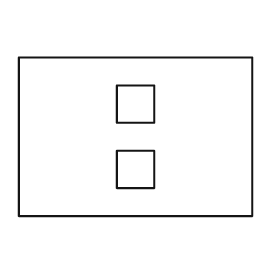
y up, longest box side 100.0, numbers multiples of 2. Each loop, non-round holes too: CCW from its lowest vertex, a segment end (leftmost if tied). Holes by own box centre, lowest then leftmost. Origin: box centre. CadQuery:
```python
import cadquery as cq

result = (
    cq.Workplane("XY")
    .moveTo(-50.0, -34.0)
    .lineTo(50.0, -34.0)
    .lineTo(50.0, 34.0)
    .lineTo(-50.0, 34.0)
    .close()
    .moveTo(-8.0, -22.0)
    .lineTo(8.0, -22.0)
    .lineTo(8.0, -6.0)
    .lineTo(-8.0, -6.0)
    .close()
    .moveTo(-8.0, 6.0)
    .lineTo(8.0, 6.0)
    .lineTo(8.0, 22.0)
    .lineTo(-8.0, 22.0)
    .close()
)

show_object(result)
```